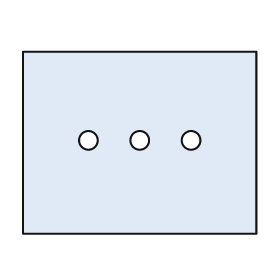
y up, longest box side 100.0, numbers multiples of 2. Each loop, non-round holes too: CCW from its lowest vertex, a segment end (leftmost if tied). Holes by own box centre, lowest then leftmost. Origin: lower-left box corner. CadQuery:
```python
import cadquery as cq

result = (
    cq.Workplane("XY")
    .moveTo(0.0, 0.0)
    .lineTo(100.0, 0.0)
    .lineTo(100.0, 78.0)
    .lineTo(0.0, 78.0)
    .close()
    .moveTo(28.0, 40.0)
    .circle(4.0)
    .moveTo(50.0, 40.0)
    .circle(4.0)
    .moveTo(72.0, 40.0)
    .circle(4.0)
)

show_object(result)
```